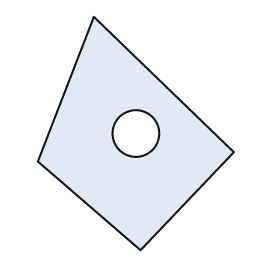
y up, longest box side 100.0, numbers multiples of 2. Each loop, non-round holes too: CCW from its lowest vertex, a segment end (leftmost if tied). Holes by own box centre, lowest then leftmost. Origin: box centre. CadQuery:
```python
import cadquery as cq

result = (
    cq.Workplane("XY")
    .moveTo(2.0, -50.0)
    .lineTo(42.0, -8.0)
    .lineTo(-18.0, 50.0)
    .lineTo(-42.0, -12.0)
    .close()
    .moveTo(0.0, 0.0)
    .circle(10.0)
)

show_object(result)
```